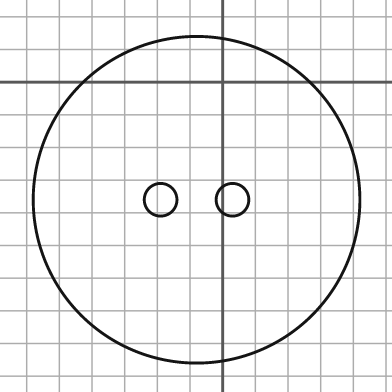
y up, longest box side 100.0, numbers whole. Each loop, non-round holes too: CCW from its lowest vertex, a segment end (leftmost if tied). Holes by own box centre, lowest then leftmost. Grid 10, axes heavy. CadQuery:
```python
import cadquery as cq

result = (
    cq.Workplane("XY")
    .moveTo(-8.0, -36.0)
    .circle(50.0)
    .moveTo(-19.0, -36.0)
    .circle(5.0)
    .moveTo(3.0, -36.0)
    .circle(5.0)
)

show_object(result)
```